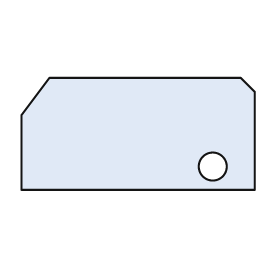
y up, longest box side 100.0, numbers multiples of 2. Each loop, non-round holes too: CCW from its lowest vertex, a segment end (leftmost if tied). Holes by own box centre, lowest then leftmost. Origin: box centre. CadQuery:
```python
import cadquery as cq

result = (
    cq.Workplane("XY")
    .moveTo(-50.0, -24.0)
    .lineTo(50.0, -24.0)
    .lineTo(50.0, 18.0)
    .lineTo(44.0, 24.0)
    .lineTo(-38.0, 24.0)
    .lineTo(-50.0, 8.0)
    .close()
    .moveTo(32.0, -14.0)
    .circle(6.0)
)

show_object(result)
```